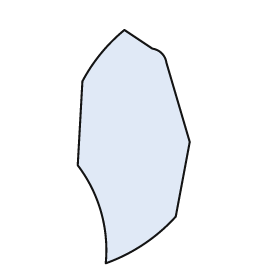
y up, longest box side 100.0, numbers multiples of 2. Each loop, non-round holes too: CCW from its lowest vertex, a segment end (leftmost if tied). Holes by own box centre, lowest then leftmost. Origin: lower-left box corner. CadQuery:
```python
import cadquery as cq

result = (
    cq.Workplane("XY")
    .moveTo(12.0, 0.0)
    .threePointArc((28.0, 8.0), (42.0, 20.0))
    .lineTo(48.0, 52.0)
    .lineTo(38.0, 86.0)
    .threePointArc((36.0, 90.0), (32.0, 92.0))
    .lineTo(20.0, 100.0)
    .threePointArc((10.0, 90.0), (2.0, 78.0))
    .lineTo(0.0, 42.0)
    .threePointArc((10.0, 22.0), (12.0, 0.0))
    .close()
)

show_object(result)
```